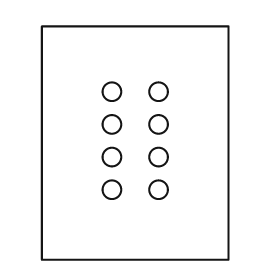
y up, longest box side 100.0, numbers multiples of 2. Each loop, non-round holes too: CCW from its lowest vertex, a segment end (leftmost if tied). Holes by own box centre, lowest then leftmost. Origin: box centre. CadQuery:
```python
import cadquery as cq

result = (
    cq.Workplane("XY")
    .moveTo(-40.0, -50.0)
    .lineTo(40.0, -50.0)
    .lineTo(40.0, 50.0)
    .lineTo(-40.0, 50.0)
    .close()
    .moveTo(-10.0, -20.0)
    .circle(4.0)
    .moveTo(10.0, -20.0)
    .circle(4.0)
    .moveTo(-10.0, -6.0)
    .circle(4.0)
    .moveTo(10.0, -6.0)
    .circle(4.0)
    .moveTo(-10.0, 8.0)
    .circle(4.0)
    .moveTo(10.0, 8.0)
    .circle(4.0)
    .moveTo(-10.0, 22.0)
    .circle(4.0)
    .moveTo(10.0, 22.0)
    .circle(4.0)
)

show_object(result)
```